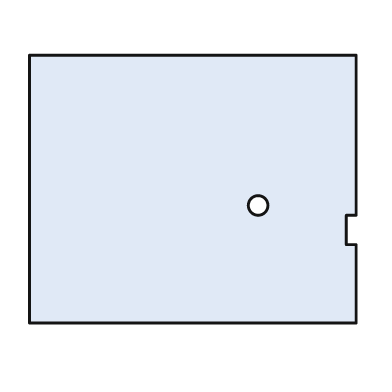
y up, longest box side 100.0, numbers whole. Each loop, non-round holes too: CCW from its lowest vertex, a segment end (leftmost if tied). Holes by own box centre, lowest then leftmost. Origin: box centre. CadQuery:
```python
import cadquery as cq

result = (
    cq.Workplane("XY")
    .moveTo(-50.0, -41.0)
    .lineTo(50.0, -41.0)
    .lineTo(50.0, -17.0)
    .lineTo(47.0, -17.0)
    .lineTo(47.0, -8.0)
    .lineTo(50.0, -8.0)
    .lineTo(50.0, 41.0)
    .lineTo(-50.0, 41.0)
    .close()
    .moveTo(20.0, -5.0)
    .circle(3.0)
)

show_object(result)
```